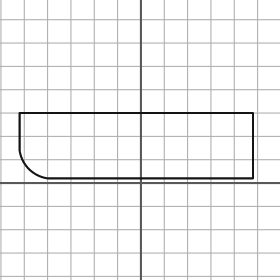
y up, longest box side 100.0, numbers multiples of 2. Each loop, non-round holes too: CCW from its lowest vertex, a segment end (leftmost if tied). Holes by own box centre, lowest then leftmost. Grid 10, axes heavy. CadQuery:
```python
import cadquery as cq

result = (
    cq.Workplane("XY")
    .moveTo(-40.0, 2.0)
    .lineTo(48.0, 2.0)
    .lineTo(48.0, 30.0)
    .lineTo(-52.0, 30.0)
    .lineTo(-52.0, 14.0)
    .threePointArc((-48.0, 6.0), (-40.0, 2.0))
    .close()
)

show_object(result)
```